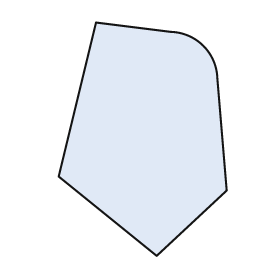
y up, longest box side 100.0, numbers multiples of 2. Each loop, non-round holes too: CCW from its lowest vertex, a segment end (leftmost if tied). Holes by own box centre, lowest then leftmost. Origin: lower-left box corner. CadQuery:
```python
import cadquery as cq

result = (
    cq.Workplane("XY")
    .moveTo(42.0, 0.0)
    .lineTo(72.0, 28.0)
    .lineTo(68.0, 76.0)
    .threePointArc((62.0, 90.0), (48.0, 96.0))
    .lineTo(16.0, 100.0)
    .lineTo(0.0, 34.0)
    .close()
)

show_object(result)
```